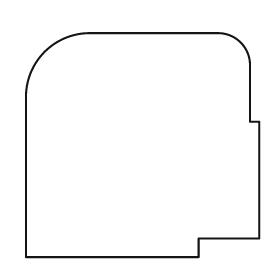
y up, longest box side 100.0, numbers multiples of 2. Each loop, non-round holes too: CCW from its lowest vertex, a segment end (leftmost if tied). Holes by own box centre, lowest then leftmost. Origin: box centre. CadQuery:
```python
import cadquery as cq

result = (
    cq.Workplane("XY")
    .moveTo(-50.0, -48.0)
    .lineTo(24.0, -48.0)
    .lineTo(24.0, -40.0)
    .lineTo(50.0, -40.0)
    .lineTo(50.0, 10.0)
    .lineTo(46.0, 10.0)
    .lineTo(46.0, 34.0)
    .threePointArc((42.0, 44.0), (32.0, 48.0))
    .lineTo(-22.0, 48.0)
    .threePointArc((-42.0, 40.0), (-50.0, 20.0))
    .close()
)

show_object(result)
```